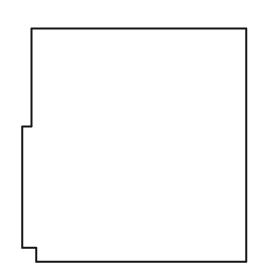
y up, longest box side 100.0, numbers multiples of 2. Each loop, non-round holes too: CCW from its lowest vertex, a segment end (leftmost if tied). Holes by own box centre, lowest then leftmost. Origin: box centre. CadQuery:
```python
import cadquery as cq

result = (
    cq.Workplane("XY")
    .moveTo(-42.0, -50.0)
    .lineTo(48.0, -50.0)
    .lineTo(48.0, 50.0)
    .lineTo(-44.0, 50.0)
    .lineTo(-44.0, 8.0)
    .lineTo(-48.0, 8.0)
    .lineTo(-48.0, -44.0)
    .lineTo(-42.0, -44.0)
    .close()
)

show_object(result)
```